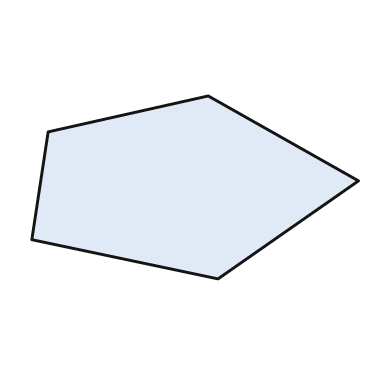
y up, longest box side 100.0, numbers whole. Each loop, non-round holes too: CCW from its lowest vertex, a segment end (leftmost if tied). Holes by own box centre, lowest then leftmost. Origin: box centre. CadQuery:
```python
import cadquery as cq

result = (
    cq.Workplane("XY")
    .moveTo(7.0, -28.0)
    .lineTo(50.0, 2.0)
    .lineTo(4.0, 28.0)
    .lineTo(-45.0, 17.0)
    .lineTo(-50.0, -16.0)
    .close()
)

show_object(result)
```